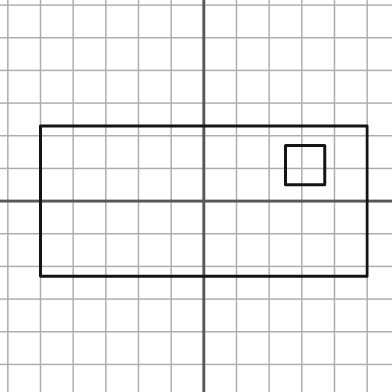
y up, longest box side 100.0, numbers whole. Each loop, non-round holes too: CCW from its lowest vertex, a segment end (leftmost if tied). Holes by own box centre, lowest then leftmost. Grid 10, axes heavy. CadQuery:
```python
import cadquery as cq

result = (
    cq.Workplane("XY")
    .moveTo(-50.0, -23.0)
    .lineTo(50.0, -23.0)
    .lineTo(50.0, 23.0)
    .lineTo(-50.0, 23.0)
    .close()
    .moveTo(25.0, 5.0)
    .lineTo(37.0, 5.0)
    .lineTo(37.0, 17.0)
    .lineTo(25.0, 17.0)
    .close()
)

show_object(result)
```